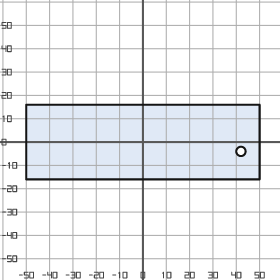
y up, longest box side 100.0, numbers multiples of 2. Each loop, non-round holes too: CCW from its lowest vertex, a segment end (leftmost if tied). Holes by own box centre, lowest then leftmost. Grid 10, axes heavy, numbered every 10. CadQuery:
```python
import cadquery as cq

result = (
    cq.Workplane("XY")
    .moveTo(-50.0, -16.0)
    .lineTo(50.0, -16.0)
    .lineTo(50.0, 16.0)
    .lineTo(-50.0, 16.0)
    .close()
    .moveTo(42.0, -4.0)
    .circle(2.0)
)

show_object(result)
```